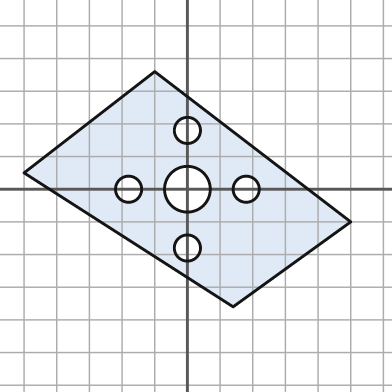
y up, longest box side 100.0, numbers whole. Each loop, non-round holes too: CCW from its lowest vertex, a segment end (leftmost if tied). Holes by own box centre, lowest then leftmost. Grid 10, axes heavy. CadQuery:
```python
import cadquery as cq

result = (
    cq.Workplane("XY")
    .moveTo(14.0, -36.0)
    .lineTo(50.0, -10.0)
    .lineTo(-10.0, 36.0)
    .lineTo(-50.0, 5.0)
    .close()
    .moveTo(0.0, -18.0)
    .circle(4.0)
    .moveTo(-18.0, 0.0)
    .circle(4.0)
    .moveTo(0.0, 0.0)
    .circle(7.0)
    .moveTo(18.0, 0.0)
    .circle(4.0)
    .moveTo(0.0, 18.0)
    .circle(4.0)
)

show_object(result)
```